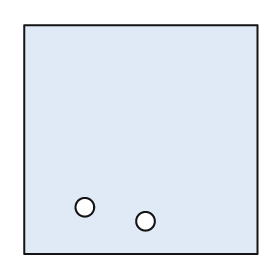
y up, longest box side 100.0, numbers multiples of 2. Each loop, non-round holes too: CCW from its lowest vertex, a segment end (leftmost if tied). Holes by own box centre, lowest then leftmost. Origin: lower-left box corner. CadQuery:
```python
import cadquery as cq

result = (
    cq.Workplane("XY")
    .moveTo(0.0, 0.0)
    .lineTo(100.0, 0.0)
    .lineTo(100.0, 98.0)
    .lineTo(0.0, 98.0)
    .close()
    .moveTo(52.0, 14.0)
    .circle(4.0)
    .moveTo(26.0, 20.0)
    .circle(4.0)
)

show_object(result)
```